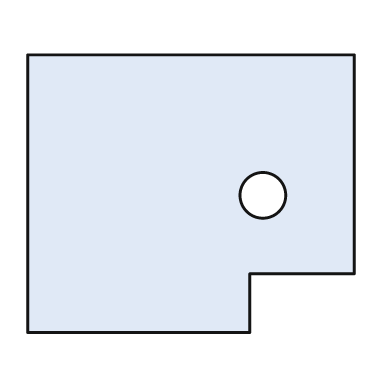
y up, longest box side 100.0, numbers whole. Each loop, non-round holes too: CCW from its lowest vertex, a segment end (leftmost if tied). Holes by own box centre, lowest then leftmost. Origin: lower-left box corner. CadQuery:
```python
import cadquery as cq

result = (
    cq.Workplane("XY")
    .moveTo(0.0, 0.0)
    .lineTo(68.0, 0.0)
    .lineTo(68.0, 18.0)
    .lineTo(100.0, 18.0)
    .lineTo(100.0, 85.0)
    .lineTo(0.0, 85.0)
    .close()
    .moveTo(72.0, 42.0)
    .circle(7.0)
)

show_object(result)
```